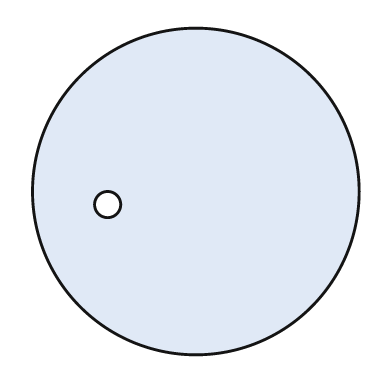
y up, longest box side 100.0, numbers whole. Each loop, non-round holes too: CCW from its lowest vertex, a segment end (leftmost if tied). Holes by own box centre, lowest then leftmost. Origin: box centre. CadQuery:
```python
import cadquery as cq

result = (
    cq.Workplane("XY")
    .moveTo(0.0, 0.0)
    .circle(50.0)
    .moveTo(-27.0, -4.0)
    .circle(4.0)
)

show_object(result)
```